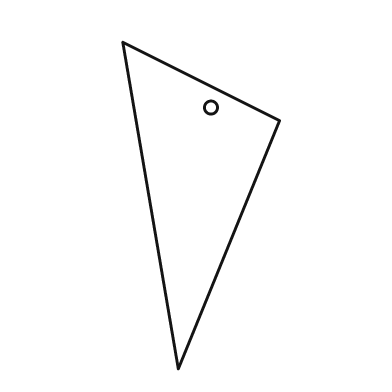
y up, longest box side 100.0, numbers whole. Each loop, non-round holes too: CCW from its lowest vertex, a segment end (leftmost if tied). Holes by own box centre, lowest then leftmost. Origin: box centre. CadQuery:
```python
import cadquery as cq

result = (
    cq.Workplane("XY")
    .moveTo(-7.0, -50.0)
    .lineTo(24.0, 26.0)
    .lineTo(-24.0, 50.0)
    .close()
    .moveTo(3.0, 30.0)
    .circle(2.0)
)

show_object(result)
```